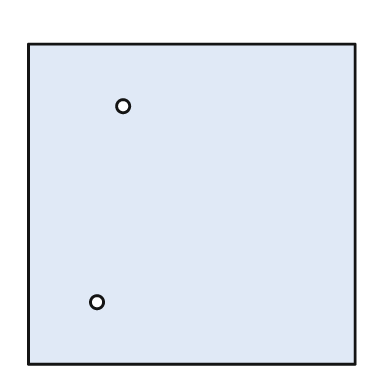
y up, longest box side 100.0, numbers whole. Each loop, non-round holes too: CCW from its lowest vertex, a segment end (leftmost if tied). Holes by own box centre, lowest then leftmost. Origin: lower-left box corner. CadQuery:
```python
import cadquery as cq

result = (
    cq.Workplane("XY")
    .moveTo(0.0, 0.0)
    .lineTo(100.0, 0.0)
    .lineTo(100.0, 98.0)
    .lineTo(0.0, 98.0)
    .close()
    .moveTo(21.0, 19.0)
    .circle(2.0)
    .moveTo(29.0, 79.0)
    .circle(2.0)
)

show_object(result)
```